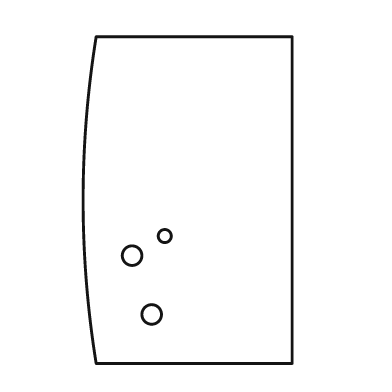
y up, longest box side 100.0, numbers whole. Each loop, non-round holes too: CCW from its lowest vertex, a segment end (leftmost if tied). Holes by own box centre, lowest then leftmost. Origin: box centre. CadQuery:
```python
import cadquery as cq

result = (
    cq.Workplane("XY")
    .moveTo(-28.0, -50.0)
    .lineTo(32.0, -50.0)
    .lineTo(32.0, 50.0)
    .lineTo(-28.0, 50.0)
    .threePointArc((-32.0, 0.0), (-28.0, -50.0))
    .close()
    .moveTo(-11.0, -35.0)
    .circle(3.0)
    .moveTo(-17.0, -17.0)
    .circle(3.0)
    .moveTo(-7.0, -11.0)
    .circle(2.0)
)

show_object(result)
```